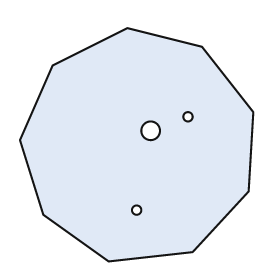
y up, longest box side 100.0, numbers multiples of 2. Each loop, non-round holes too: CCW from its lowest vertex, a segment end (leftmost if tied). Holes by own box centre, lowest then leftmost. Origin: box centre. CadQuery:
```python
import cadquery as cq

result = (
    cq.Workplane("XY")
    .moveTo(-12.0, -50.0)
    .lineTo(24.0, -46.0)
    .lineTo(48.0, -20.0)
    .lineTo(50.0, 14.0)
    .lineTo(28.0, 42.0)
    .lineTo(-4.0, 50.0)
    .lineTo(-36.0, 34.0)
    .lineTo(-50.0, 2.0)
    .lineTo(-40.0, -30.0)
    .close()
    .moveTo(0.0, -28.0)
    .circle(2.0)
    .moveTo(6.0, 6.0)
    .circle(4.0)
    .moveTo(22.0, 12.0)
    .circle(2.0)
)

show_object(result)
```